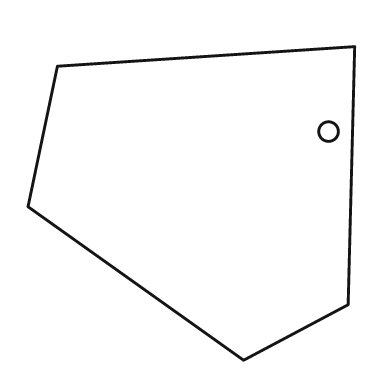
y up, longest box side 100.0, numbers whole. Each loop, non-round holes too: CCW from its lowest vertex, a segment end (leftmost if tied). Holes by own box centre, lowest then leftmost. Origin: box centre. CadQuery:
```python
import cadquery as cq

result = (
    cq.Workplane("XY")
    .moveTo(16.0, -48.0)
    .lineTo(48.0, -31.0)
    .lineTo(50.0, 48.0)
    .lineTo(-41.0, 42.0)
    .lineTo(-50.0, -1.0)
    .close()
    .moveTo(42.0, 22.0)
    .circle(3.0)
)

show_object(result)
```